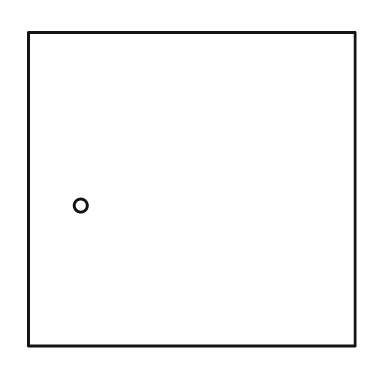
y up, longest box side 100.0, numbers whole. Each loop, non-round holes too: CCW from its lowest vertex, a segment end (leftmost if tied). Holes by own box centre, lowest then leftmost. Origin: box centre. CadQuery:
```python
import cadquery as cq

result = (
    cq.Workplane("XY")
    .moveTo(-50.0, -48.0)
    .lineTo(50.0, -48.0)
    .lineTo(50.0, 48.0)
    .lineTo(-50.0, 48.0)
    .close()
    .moveTo(-34.0, -5.0)
    .circle(2.0)
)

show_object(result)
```